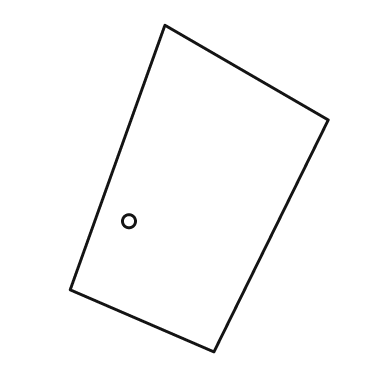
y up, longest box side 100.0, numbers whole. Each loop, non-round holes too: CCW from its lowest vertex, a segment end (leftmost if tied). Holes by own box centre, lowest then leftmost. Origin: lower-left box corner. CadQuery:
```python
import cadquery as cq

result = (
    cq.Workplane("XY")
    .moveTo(44.0, 0.0)
    .lineTo(79.0, 71.0)
    .lineTo(29.0, 100.0)
    .lineTo(0.0, 19.0)
    .close()
    .moveTo(18.0, 40.0)
    .circle(2.0)
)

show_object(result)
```